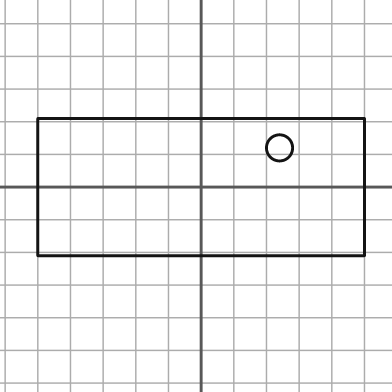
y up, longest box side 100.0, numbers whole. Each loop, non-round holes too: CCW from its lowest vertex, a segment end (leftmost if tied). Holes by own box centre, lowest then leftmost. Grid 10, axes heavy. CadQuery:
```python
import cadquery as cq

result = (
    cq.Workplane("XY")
    .moveTo(-50.0, -21.0)
    .lineTo(50.0, -21.0)
    .lineTo(50.0, 21.0)
    .lineTo(-50.0, 21.0)
    .close()
    .moveTo(24.0, 12.0)
    .circle(4.0)
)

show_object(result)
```